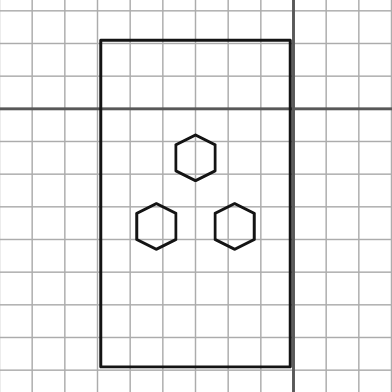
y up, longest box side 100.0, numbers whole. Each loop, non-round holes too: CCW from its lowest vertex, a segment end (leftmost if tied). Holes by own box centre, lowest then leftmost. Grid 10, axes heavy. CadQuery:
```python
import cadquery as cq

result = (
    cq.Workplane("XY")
    .moveTo(-59.0, -79.0)
    .lineTo(-1.0, -79.0)
    .lineTo(-1.0, 21.0)
    .lineTo(-59.0, 21.0)
    .close()
    .moveTo(-42.0, -43.0)
    .lineTo(-36.0, -40.0)
    .lineTo(-36.0, -32.0)
    .lineTo(-42.0, -29.0)
    .lineTo(-48.0, -32.0)
    .lineTo(-48.0, -40.0)
    .close()
    .moveTo(-18.0, -43.0)
    .lineTo(-12.0, -40.0)
    .lineTo(-12.0, -32.0)
    .lineTo(-18.0, -29.0)
    .lineTo(-24.0, -32.0)
    .lineTo(-24.0, -40.0)
    .close()
    .moveTo(-30.0, -22.0)
    .lineTo(-24.0, -19.0)
    .lineTo(-24.0, -11.0)
    .lineTo(-30.0, -8.0)
    .lineTo(-36.0, -11.0)
    .lineTo(-36.0, -19.0)
    .close()
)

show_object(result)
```